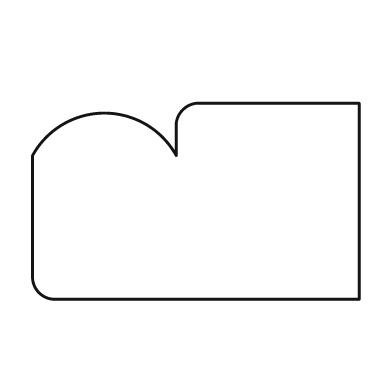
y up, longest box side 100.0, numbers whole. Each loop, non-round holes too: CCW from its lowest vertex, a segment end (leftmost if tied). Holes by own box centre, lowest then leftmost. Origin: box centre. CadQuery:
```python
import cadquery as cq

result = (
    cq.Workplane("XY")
    .moveTo(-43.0, -30.0)
    .lineTo(50.0, -30.0)
    .lineTo(50.0, 30.0)
    .lineTo(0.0, 30.0)
    .threePointArc((-4.0, 28.0), (-6.0, 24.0))
    .lineTo(-6.0, 14.0)
    .threePointArc((-28.0, 27.0), (-50.0, 14.0))
    .lineTo(-50.0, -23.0)
    .threePointArc((-48.0, -28.0), (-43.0, -30.0))
    .close()
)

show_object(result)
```